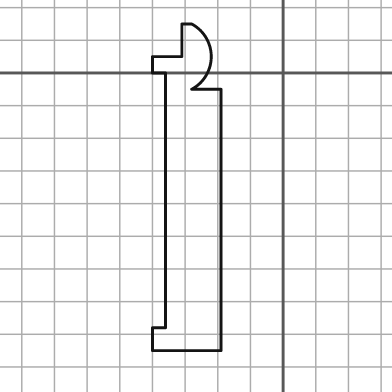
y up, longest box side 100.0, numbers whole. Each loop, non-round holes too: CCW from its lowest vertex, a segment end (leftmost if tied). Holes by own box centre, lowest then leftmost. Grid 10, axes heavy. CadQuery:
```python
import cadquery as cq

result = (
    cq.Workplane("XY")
    .moveTo(-40.0, -85.0)
    .lineTo(-19.0, -85.0)
    .lineTo(-19.0, -5.0)
    .lineTo(-28.0, -5.0)
    .threePointArc((-22.0, 5.0), (-28.0, 15.0))
    .lineTo(-31.0, 15.0)
    .lineTo(-31.0, 5.0)
    .lineTo(-40.0, 5.0)
    .lineTo(-40.0, 0.0)
    .lineTo(-36.0, 0.0)
    .lineTo(-36.0, -78.0)
    .lineTo(-40.0, -78.0)
    .close()
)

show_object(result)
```